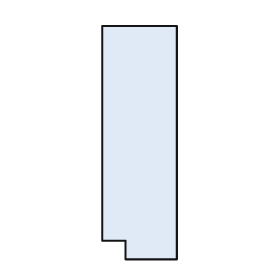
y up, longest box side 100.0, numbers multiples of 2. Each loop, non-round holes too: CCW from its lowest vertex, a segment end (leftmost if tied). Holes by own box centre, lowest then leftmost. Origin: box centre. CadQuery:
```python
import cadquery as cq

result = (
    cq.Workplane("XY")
    .moveTo(-6.0, -50.0)
    .lineTo(16.0, -50.0)
    .lineTo(16.0, 50.0)
    .lineTo(-16.0, 50.0)
    .lineTo(-16.0, -42.0)
    .lineTo(-6.0, -42.0)
    .close()
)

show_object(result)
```